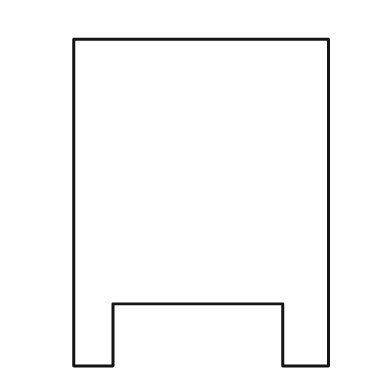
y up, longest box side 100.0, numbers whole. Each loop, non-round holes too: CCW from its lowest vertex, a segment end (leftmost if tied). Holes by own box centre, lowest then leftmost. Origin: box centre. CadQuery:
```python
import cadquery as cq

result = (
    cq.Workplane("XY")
    .moveTo(-39.0, -50.0)
    .lineTo(-27.0, -50.0)
    .lineTo(-27.0, -31.0)
    .lineTo(25.0, -31.0)
    .lineTo(25.0, -50.0)
    .lineTo(39.0, -50.0)
    .lineTo(39.0, 50.0)
    .lineTo(-39.0, 50.0)
    .close()
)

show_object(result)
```